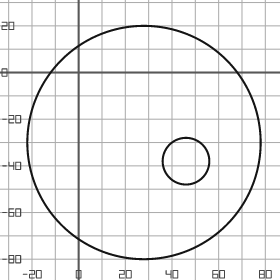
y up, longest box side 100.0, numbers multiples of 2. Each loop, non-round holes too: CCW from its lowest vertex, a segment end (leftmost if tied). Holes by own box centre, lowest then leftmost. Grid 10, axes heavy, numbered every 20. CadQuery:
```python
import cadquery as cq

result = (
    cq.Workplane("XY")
    .moveTo(28.0, -30.0)
    .circle(50.0)
    .moveTo(46.0, -38.0)
    .circle(10.0)
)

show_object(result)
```